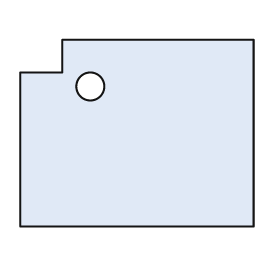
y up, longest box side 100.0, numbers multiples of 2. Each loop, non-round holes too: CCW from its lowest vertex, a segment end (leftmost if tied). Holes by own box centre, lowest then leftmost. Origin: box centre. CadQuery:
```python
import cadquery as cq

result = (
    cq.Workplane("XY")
    .moveTo(-50.0, -40.0)
    .lineTo(50.0, -40.0)
    .lineTo(50.0, 40.0)
    .lineTo(-32.0, 40.0)
    .lineTo(-32.0, 26.0)
    .lineTo(-50.0, 26.0)
    .close()
    .moveTo(-20.0, 20.0)
    .circle(6.0)
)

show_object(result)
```